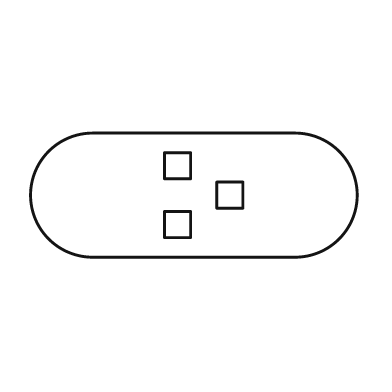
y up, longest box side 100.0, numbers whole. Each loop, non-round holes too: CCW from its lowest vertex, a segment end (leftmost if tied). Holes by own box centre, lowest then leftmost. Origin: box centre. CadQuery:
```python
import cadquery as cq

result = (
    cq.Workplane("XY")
    .moveTo(-31.0, -19.0)
    .lineTo(31.0, -19.0)
    .threePointArc((50.0, 0.0), (31.0, 19.0))
    .lineTo(-31.0, 19.0)
    .threePointArc((-50.0, 0.0), (-31.0, -19.0))
    .close()
    .moveTo(-9.0, -13.0)
    .lineTo(-1.0, -13.0)
    .lineTo(-1.0, -5.0)
    .lineTo(-9.0, -5.0)
    .close()
    .moveTo(7.0, -4.0)
    .lineTo(15.0, -4.0)
    .lineTo(15.0, 4.0)
    .lineTo(7.0, 4.0)
    .close()
    .moveTo(-9.0, 5.0)
    .lineTo(-1.0, 5.0)
    .lineTo(-1.0, 13.0)
    .lineTo(-9.0, 13.0)
    .close()
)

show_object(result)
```